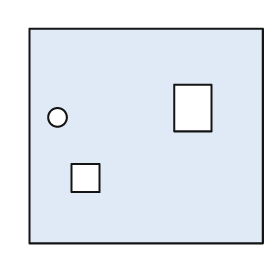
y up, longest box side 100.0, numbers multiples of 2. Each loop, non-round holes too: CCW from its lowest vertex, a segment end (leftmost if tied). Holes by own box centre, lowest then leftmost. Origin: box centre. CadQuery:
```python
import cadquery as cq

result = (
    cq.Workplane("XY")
    .moveTo(-50.0, -46.0)
    .lineTo(50.0, -46.0)
    .lineTo(50.0, 46.0)
    .lineTo(-50.0, 46.0)
    .close()
    .moveTo(-32.0, -24.0)
    .lineTo(-20.0, -24.0)
    .lineTo(-20.0, -12.0)
    .lineTo(-32.0, -12.0)
    .close()
    .moveTo(-38.0, 8.0)
    .circle(4.0)
    .moveTo(12.0, 2.0)
    .lineTo(28.0, 2.0)
    .lineTo(28.0, 22.0)
    .lineTo(12.0, 22.0)
    .close()
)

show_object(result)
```